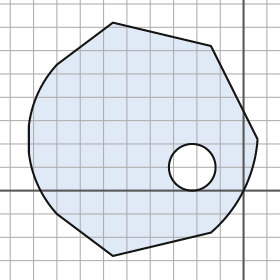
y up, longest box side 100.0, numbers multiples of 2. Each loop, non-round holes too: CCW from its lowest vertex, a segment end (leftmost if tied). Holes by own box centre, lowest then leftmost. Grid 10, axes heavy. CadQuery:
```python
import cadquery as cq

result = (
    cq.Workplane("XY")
    .moveTo(-56.0, -28.0)
    .lineTo(-14.0, -18.0)
    .threePointArc((0.0, 0.0), (6.0, 22.0))
    .lineTo(-14.0, 62.0)
    .lineTo(-56.0, 72.0)
    .lineTo(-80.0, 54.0)
    .threePointArc((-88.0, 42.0), (-92.0, 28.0))
    .lineTo(-92.0, 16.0)
    .threePointArc((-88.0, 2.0), (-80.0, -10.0))
    .close()
    .moveTo(-22.0, 10.0)
    .circle(10.0)
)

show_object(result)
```